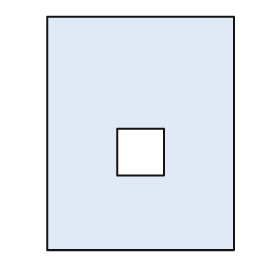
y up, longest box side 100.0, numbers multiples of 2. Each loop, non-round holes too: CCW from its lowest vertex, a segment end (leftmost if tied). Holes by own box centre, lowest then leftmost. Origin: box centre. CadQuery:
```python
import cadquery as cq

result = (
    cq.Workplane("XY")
    .moveTo(-40.0, -50.0)
    .lineTo(40.0, -50.0)
    .lineTo(40.0, 50.0)
    .lineTo(-40.0, 50.0)
    .close()
    .moveTo(-10.0, -18.0)
    .lineTo(10.0, -18.0)
    .lineTo(10.0, 2.0)
    .lineTo(-10.0, 2.0)
    .close()
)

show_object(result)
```